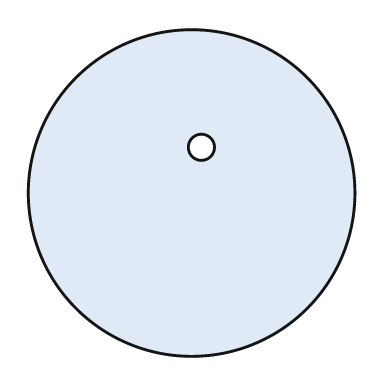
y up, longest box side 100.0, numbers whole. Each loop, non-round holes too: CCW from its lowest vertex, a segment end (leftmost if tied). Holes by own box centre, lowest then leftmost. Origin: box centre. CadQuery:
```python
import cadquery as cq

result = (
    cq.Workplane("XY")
    .moveTo(0.0, 0.0)
    .circle(50.0)
    .moveTo(3.0, 14.0)
    .circle(4.0)
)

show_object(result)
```